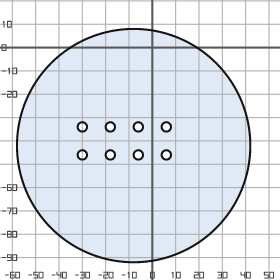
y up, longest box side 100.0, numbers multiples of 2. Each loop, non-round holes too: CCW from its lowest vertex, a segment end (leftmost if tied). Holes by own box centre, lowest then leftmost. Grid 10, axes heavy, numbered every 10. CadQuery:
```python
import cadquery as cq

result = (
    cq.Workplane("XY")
    .moveTo(-8.0, -42.0)
    .circle(50.0)
    .moveTo(-30.0, -46.0)
    .circle(2.0)
    .moveTo(-18.0, -46.0)
    .circle(2.0)
    .moveTo(-6.0, -46.0)
    .circle(2.0)
    .moveTo(6.0, -46.0)
    .circle(2.0)
    .moveTo(-30.0, -34.0)
    .circle(2.0)
    .moveTo(-18.0, -34.0)
    .circle(2.0)
    .moveTo(-6.0, -34.0)
    .circle(2.0)
    .moveTo(6.0, -34.0)
    .circle(2.0)
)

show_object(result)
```